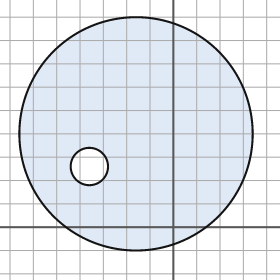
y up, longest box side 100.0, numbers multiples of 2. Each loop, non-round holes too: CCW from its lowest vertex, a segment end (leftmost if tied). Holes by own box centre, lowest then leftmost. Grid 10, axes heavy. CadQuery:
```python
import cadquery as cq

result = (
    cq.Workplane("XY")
    .moveTo(-16.0, 40.0)
    .circle(50.0)
    .moveTo(-36.0, 26.0)
    .circle(8.0)
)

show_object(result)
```